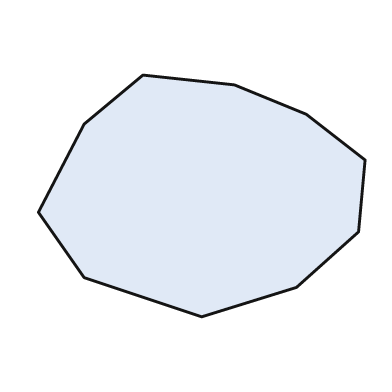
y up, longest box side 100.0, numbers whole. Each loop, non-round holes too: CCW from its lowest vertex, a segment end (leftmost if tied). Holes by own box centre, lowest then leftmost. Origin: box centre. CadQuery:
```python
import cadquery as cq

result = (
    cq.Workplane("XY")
    .moveTo(0.0, -37.0)
    .lineTo(29.0, -28.0)
    .lineTo(48.0, -11.0)
    .lineTo(50.0, 11.0)
    .lineTo(32.0, 25.0)
    .lineTo(10.0, 34.0)
    .lineTo(-18.0, 37.0)
    .lineTo(-36.0, 22.0)
    .lineTo(-50.0, -5.0)
    .lineTo(-36.0, -25.0)
    .close()
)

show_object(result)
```